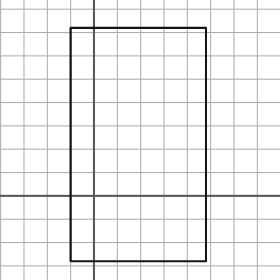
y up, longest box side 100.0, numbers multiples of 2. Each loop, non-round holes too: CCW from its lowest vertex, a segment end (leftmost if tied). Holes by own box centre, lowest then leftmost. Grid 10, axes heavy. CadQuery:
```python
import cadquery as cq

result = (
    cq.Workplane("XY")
    .moveTo(-10.0, -28.0)
    .lineTo(48.0, -28.0)
    .lineTo(48.0, 72.0)
    .lineTo(-10.0, 72.0)
    .close()
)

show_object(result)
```